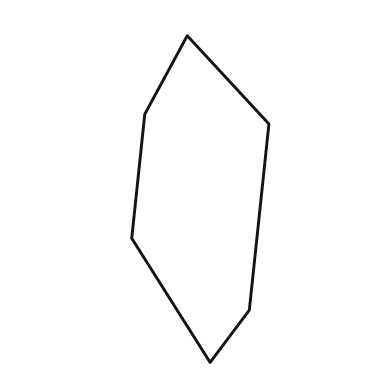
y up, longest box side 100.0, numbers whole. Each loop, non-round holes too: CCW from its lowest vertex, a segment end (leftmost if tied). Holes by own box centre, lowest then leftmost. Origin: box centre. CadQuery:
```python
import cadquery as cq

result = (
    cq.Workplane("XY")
    .moveTo(3.0, -50.0)
    .lineTo(15.0, -34.0)
    .lineTo(21.0, 23.0)
    .lineTo(-4.0, 50.0)
    .lineTo(-17.0, 26.0)
    .lineTo(-21.0, -12.0)
    .close()
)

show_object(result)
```